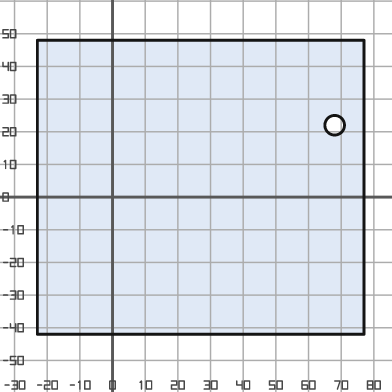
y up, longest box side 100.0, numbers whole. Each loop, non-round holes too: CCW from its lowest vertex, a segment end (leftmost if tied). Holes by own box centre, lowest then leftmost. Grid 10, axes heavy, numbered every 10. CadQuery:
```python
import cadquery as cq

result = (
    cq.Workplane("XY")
    .moveTo(-23.0, -42.0)
    .lineTo(77.0, -42.0)
    .lineTo(77.0, 48.0)
    .lineTo(-23.0, 48.0)
    .close()
    .moveTo(68.0, 22.0)
    .circle(3.0)
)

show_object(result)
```